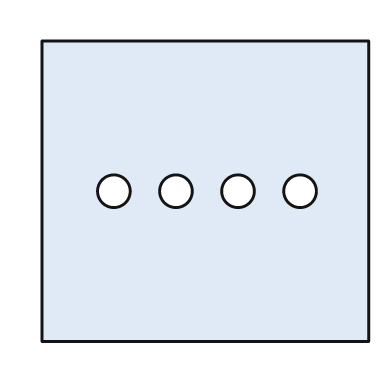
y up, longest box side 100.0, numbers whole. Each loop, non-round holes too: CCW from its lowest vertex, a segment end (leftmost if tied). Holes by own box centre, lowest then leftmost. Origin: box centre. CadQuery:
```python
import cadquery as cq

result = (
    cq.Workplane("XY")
    .moveTo(-50.0, -46.0)
    .lineTo(50.0, -46.0)
    .lineTo(50.0, 46.0)
    .lineTo(-50.0, 46.0)
    .close()
    .moveTo(-28.0, 0.0)
    .circle(5.0)
    .moveTo(-9.0, 0.0)
    .circle(5.0)
    .moveTo(10.0, 0.0)
    .circle(5.0)
    .moveTo(29.0, 0.0)
    .circle(5.0)
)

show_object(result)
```